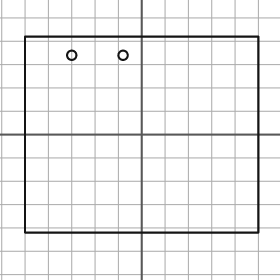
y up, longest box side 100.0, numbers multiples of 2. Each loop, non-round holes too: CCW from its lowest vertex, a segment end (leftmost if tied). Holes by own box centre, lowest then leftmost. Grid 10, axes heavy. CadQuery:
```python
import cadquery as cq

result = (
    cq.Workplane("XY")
    .moveTo(-50.0, -42.0)
    .lineTo(50.0, -42.0)
    .lineTo(50.0, 42.0)
    .lineTo(-50.0, 42.0)
    .close()
    .moveTo(-30.0, 34.0)
    .circle(2.0)
    .moveTo(-8.0, 34.0)
    .circle(2.0)
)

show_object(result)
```